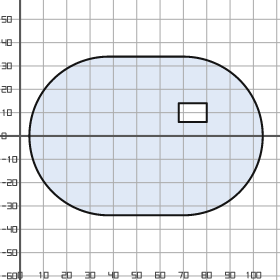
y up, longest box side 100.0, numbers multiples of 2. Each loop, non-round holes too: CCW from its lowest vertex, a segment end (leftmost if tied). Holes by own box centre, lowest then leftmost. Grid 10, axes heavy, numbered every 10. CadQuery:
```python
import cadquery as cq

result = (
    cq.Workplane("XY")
    .moveTo(38.0, -34.0)
    .lineTo(70.0, -34.0)
    .threePointArc((104.0, 0.0), (70.0, 34.0))
    .lineTo(38.0, 34.0)
    .threePointArc((4.0, 0.0), (38.0, -34.0))
    .close()
    .moveTo(68.0, 6.0)
    .lineTo(80.0, 6.0)
    .lineTo(80.0, 14.0)
    .lineTo(68.0, 14.0)
    .close()
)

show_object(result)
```